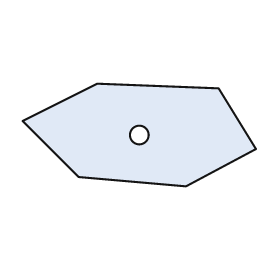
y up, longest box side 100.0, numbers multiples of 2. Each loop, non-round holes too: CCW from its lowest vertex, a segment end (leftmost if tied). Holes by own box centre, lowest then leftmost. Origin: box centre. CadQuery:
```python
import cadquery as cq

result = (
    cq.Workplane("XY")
    .moveTo(20.0, -22.0)
    .lineTo(50.0, -6.0)
    .lineTo(34.0, 20.0)
    .lineTo(-18.0, 22.0)
    .lineTo(-50.0, 6.0)
    .lineTo(-26.0, -18.0)
    .close()
    .moveTo(0.0, 0.0)
    .circle(4.0)
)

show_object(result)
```